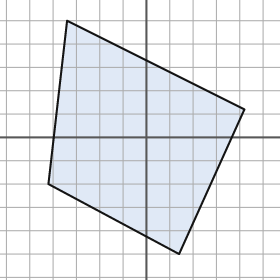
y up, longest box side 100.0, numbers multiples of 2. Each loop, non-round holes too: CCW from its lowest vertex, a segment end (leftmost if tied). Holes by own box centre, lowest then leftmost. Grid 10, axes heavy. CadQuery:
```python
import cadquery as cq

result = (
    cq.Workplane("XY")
    .moveTo(14.0, -50.0)
    .lineTo(42.0, 12.0)
    .lineTo(-34.0, 50.0)
    .lineTo(-42.0, -20.0)
    .close()
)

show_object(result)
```